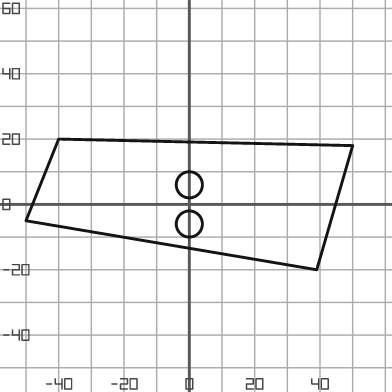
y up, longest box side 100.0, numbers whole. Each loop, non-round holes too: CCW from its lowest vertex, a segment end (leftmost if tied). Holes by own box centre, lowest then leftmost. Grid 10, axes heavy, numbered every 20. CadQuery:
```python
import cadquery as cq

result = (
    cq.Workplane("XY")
    .moveTo(39.0, -20.0)
    .lineTo(50.0, 18.0)
    .lineTo(-40.0, 20.0)
    .lineTo(-50.0, -5.0)
    .close()
    .moveTo(0.0, -6.0)
    .circle(4.0)
    .moveTo(0.0, 6.0)
    .circle(4.0)
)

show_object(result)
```